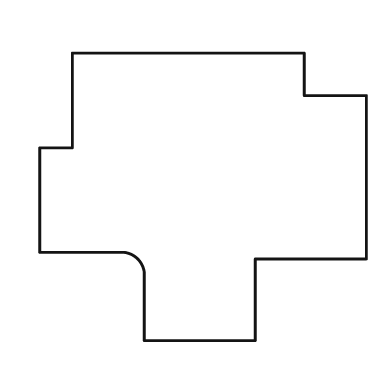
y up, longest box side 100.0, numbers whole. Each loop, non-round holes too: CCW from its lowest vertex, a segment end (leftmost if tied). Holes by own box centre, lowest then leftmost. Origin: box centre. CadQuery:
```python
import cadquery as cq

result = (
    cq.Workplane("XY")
    .moveTo(-18.0, -44.0)
    .lineTo(16.0, -44.0)
    .lineTo(16.0, -19.0)
    .lineTo(50.0, -19.0)
    .lineTo(50.0, 31.0)
    .lineTo(31.0, 31.0)
    .lineTo(31.0, 44.0)
    .lineTo(-40.0, 44.0)
    .lineTo(-40.0, 15.0)
    .lineTo(-50.0, 15.0)
    .lineTo(-50.0, -17.0)
    .lineTo(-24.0, -17.0)
    .threePointArc((-20.0, -19.0), (-18.0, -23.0))
    .close()
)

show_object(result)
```